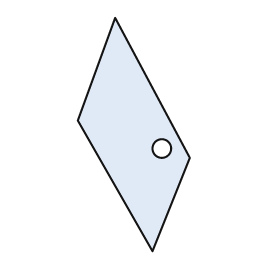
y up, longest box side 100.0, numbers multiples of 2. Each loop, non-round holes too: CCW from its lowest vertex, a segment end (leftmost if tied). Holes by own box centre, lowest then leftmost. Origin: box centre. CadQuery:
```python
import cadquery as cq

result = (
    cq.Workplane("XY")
    .moveTo(8.0, -50.0)
    .lineTo(24.0, -10.0)
    .lineTo(-8.0, 50.0)
    .lineTo(-24.0, 6.0)
    .close()
    .moveTo(12.0, -6.0)
    .circle(4.0)
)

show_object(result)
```